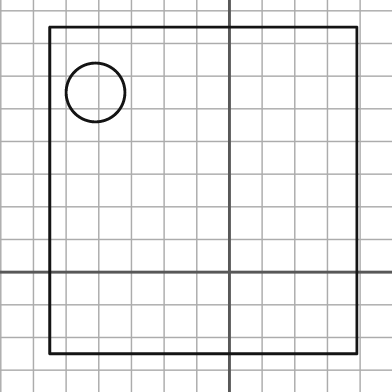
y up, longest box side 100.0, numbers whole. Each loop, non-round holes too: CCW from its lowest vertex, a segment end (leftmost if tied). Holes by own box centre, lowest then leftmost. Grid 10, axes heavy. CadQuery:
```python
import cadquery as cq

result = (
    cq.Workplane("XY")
    .moveTo(-55.0, -25.0)
    .lineTo(39.0, -25.0)
    .lineTo(39.0, 75.0)
    .lineTo(-55.0, 75.0)
    .close()
    .moveTo(-41.0, 55.0)
    .circle(9.0)
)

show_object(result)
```